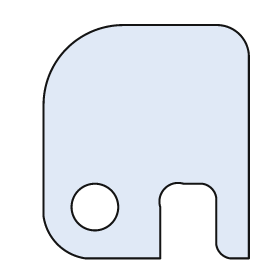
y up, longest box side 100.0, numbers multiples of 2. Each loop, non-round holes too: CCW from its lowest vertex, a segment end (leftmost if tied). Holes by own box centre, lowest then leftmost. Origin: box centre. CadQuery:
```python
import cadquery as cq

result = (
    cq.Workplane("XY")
    .moveTo(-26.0, -50.0)
    .lineTo(6.0, -50.0)
    .lineTo(6.0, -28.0)
    .threePointArc((8.0, -20.0), (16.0, -18.0))
    .lineTo(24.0, -18.0)
    .threePointArc((28.0, -20.0), (30.0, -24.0))
    .lineTo(30.0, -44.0)
    .threePointArc((32.0, -48.0), (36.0, -50.0))
    .lineTo(44.0, -50.0)
    .lineTo(44.0, 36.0)
    .threePointArc((40.0, 46.0), (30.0, 50.0))
    .lineTo(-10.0, 50.0)
    .threePointArc((-34.0, 40.0), (-44.0, 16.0))
    .lineTo(-44.0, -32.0)
    .threePointArc((-38.0, -44.0), (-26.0, -50.0))
    .close()
    .moveTo(-22.0, -28.0)
    .circle(10.0)
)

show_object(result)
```